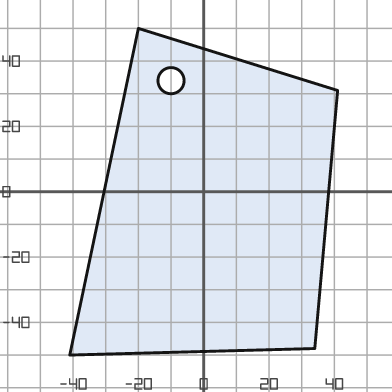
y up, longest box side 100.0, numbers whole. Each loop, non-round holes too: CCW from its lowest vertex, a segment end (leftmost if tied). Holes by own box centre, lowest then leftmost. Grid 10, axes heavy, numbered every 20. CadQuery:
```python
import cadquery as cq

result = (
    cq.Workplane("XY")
    .moveTo(-41.0, -50.0)
    .lineTo(34.0, -48.0)
    .lineTo(41.0, 31.0)
    .lineTo(-20.0, 50.0)
    .close()
    .moveTo(-10.0, 34.0)
    .circle(4.0)
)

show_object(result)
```